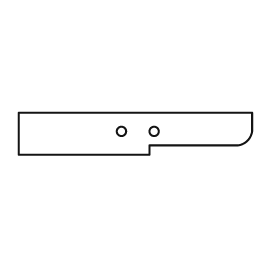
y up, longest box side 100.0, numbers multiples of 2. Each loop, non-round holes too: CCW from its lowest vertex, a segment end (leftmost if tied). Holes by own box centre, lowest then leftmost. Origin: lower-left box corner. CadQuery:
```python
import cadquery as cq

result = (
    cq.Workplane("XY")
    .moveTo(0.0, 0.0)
    .lineTo(56.0, 0.0)
    .lineTo(56.0, 4.0)
    .lineTo(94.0, 4.0)
    .threePointArc((98.0, 6.0), (100.0, 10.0))
    .lineTo(100.0, 18.0)
    .lineTo(0.0, 18.0)
    .close()
    .moveTo(44.0, 10.0)
    .circle(2.0)
    .moveTo(58.0, 10.0)
    .circle(2.0)
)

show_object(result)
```